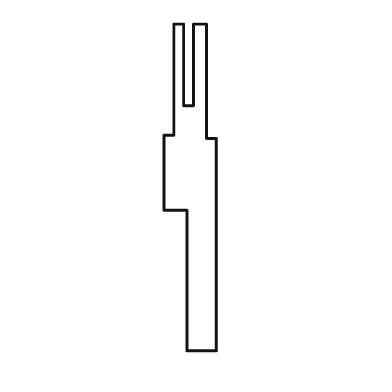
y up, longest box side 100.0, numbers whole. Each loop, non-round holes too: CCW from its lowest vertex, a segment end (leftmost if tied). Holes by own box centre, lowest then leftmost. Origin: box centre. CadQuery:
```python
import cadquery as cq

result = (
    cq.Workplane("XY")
    .moveTo(-1.0, -50.0)
    .lineTo(8.0, -50.0)
    .lineTo(8.0, 15.0)
    .lineTo(5.0, 15.0)
    .lineTo(5.0, 50.0)
    .lineTo(1.0, 50.0)
    .lineTo(1.0, 25.0)
    .lineTo(-2.0, 25.0)
    .lineTo(-2.0, 50.0)
    .lineTo(-5.0, 50.0)
    .lineTo(-5.0, 16.0)
    .lineTo(-8.0, 16.0)
    .lineTo(-8.0, -7.0)
    .lineTo(-1.0, -7.0)
    .close()
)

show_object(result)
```